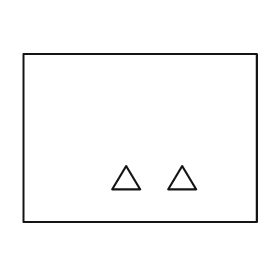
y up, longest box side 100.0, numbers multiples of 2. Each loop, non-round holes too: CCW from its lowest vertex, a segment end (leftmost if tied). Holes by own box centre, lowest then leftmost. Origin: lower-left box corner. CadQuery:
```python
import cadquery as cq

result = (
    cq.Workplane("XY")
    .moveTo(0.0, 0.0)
    .lineTo(100.0, 0.0)
    .lineTo(100.0, 72.0)
    .lineTo(0.0, 72.0)
    .close()
    .moveTo(38.0, 14.0)
    .lineTo(50.0, 14.0)
    .lineTo(44.0, 24.0)
    .close()
    .moveTo(62.0, 14.0)
    .lineTo(74.0, 14.0)
    .lineTo(68.0, 24.0)
    .close()
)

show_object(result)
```